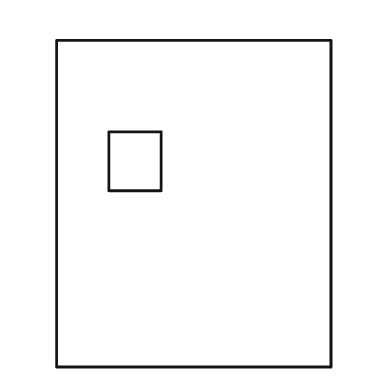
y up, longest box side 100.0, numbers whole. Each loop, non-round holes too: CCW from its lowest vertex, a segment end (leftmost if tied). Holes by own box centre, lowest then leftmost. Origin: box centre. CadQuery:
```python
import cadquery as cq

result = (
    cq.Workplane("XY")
    .moveTo(-42.0, -50.0)
    .lineTo(42.0, -50.0)
    .lineTo(42.0, 50.0)
    .lineTo(-42.0, 50.0)
    .close()
    .moveTo(-26.0, 4.0)
    .lineTo(-10.0, 4.0)
    .lineTo(-10.0, 22.0)
    .lineTo(-26.0, 22.0)
    .close()
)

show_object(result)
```